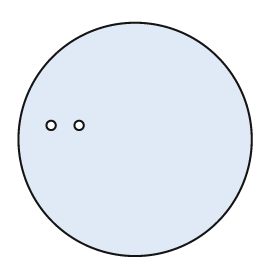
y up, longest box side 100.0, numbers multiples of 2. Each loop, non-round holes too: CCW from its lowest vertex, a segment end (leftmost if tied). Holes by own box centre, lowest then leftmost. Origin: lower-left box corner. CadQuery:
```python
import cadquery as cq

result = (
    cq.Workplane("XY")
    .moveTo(50.0, 50.0)
    .circle(50.0)
    .moveTo(14.0, 56.0)
    .circle(2.0)
    .moveTo(26.0, 56.0)
    .circle(2.0)
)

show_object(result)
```